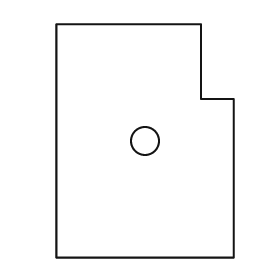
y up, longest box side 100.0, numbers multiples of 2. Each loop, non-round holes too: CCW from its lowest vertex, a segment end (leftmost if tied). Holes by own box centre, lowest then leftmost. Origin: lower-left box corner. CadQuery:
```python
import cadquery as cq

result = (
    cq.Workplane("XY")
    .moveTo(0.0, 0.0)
    .lineTo(76.0, 0.0)
    .lineTo(76.0, 68.0)
    .lineTo(62.0, 68.0)
    .lineTo(62.0, 100.0)
    .lineTo(0.0, 100.0)
    .close()
    .moveTo(38.0, 50.0)
    .circle(6.0)
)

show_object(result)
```